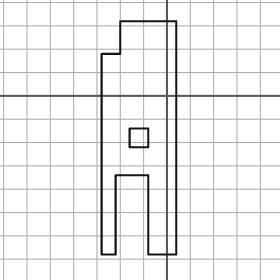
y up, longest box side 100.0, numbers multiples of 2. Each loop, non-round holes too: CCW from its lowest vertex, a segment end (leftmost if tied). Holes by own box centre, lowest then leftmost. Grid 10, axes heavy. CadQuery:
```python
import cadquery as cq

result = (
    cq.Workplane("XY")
    .moveTo(-28.0, -68.0)
    .lineTo(-22.0, -68.0)
    .lineTo(-22.0, -34.0)
    .lineTo(-8.0, -34.0)
    .lineTo(-8.0, -68.0)
    .lineTo(4.0, -68.0)
    .lineTo(4.0, 32.0)
    .lineTo(-20.0, 32.0)
    .lineTo(-20.0, 18.0)
    .lineTo(-28.0, 18.0)
    .close()
    .moveTo(-16.0, -22.0)
    .lineTo(-8.0, -22.0)
    .lineTo(-8.0, -14.0)
    .lineTo(-16.0, -14.0)
    .close()
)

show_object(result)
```